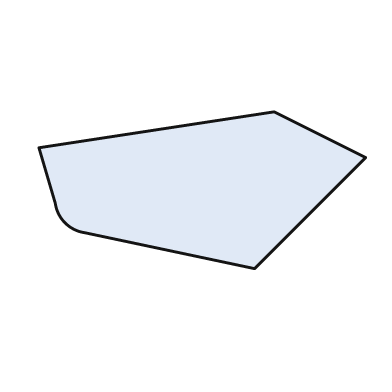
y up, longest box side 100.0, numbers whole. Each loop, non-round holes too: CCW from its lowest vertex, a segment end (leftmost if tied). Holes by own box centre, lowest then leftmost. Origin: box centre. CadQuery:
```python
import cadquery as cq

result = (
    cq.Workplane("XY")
    .moveTo(16.0, -24.0)
    .lineTo(50.0, 10.0)
    .lineTo(22.0, 24.0)
    .lineTo(-50.0, 13.0)
    .lineTo(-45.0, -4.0)
    .threePointArc((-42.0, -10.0), (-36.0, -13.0))
    .close()
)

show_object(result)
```